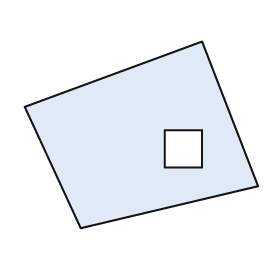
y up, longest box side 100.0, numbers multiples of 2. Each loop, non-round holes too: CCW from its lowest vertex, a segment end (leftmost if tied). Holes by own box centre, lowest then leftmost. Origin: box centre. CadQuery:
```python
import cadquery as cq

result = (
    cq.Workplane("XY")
    .moveTo(-26.0, -40.0)
    .lineTo(50.0, -22.0)
    .lineTo(26.0, 40.0)
    .lineTo(-50.0, 12.0)
    .close()
    .moveTo(10.0, -14.0)
    .lineTo(26.0, -14.0)
    .lineTo(26.0, 2.0)
    .lineTo(10.0, 2.0)
    .close()
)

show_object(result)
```